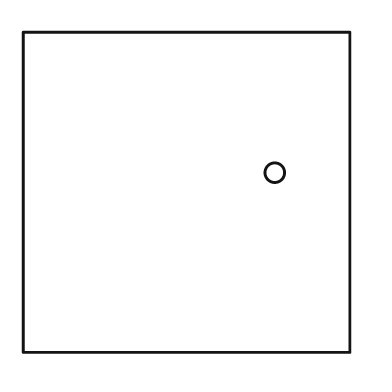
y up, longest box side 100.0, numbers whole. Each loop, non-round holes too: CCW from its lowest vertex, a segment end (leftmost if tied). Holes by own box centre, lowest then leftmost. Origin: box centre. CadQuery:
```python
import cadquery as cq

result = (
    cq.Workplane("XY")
    .moveTo(-50.0, -49.0)
    .lineTo(50.0, -49.0)
    .lineTo(50.0, 49.0)
    .lineTo(-50.0, 49.0)
    .close()
    .moveTo(27.0, 6.0)
    .circle(3.0)
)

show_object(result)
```